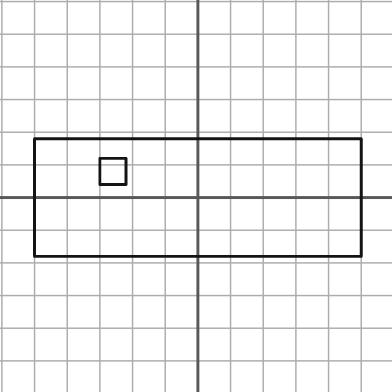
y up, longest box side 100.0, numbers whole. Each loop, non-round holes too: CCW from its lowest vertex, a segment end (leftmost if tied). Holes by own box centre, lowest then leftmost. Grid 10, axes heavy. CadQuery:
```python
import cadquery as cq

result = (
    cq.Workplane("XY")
    .moveTo(-50.0, -18.0)
    .lineTo(50.0, -18.0)
    .lineTo(50.0, 18.0)
    .lineTo(-50.0, 18.0)
    .close()
    .moveTo(-30.0, 4.0)
    .lineTo(-22.0, 4.0)
    .lineTo(-22.0, 12.0)
    .lineTo(-30.0, 12.0)
    .close()
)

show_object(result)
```